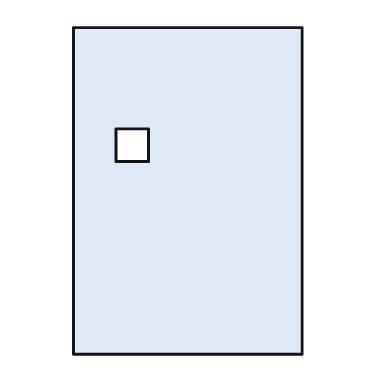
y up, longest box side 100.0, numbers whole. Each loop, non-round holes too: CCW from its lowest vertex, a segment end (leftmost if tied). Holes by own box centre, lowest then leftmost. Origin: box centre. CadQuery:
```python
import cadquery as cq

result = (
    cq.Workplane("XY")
    .moveTo(-35.0, -50.0)
    .lineTo(35.0, -50.0)
    .lineTo(35.0, 50.0)
    .lineTo(-35.0, 50.0)
    .close()
    .moveTo(-22.0, 9.0)
    .lineTo(-12.0, 9.0)
    .lineTo(-12.0, 19.0)
    .lineTo(-22.0, 19.0)
    .close()
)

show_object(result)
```